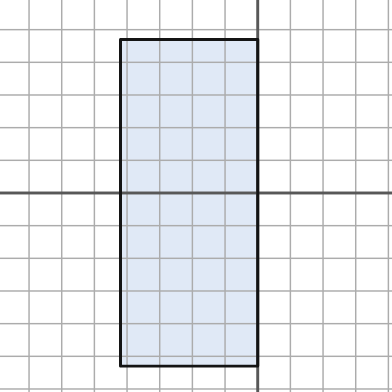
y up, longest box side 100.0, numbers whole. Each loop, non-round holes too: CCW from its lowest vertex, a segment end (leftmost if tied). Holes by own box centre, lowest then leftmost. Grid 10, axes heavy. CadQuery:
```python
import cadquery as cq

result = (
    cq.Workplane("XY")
    .moveTo(-42.0, -53.0)
    .lineTo(0.0, -53.0)
    .lineTo(0.0, 47.0)
    .lineTo(-42.0, 47.0)
    .close()
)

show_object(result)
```